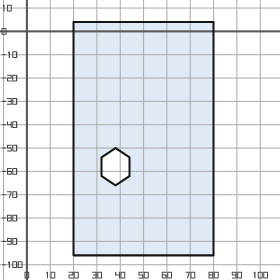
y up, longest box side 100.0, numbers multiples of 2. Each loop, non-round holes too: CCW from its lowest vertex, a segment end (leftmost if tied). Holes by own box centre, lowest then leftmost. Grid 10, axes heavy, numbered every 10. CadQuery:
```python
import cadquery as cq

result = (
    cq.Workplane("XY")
    .moveTo(20.0, -96.0)
    .lineTo(80.0, -96.0)
    .lineTo(80.0, 4.0)
    .lineTo(20.0, 4.0)
    .close()
    .moveTo(38.0, -66.0)
    .lineTo(44.0, -62.0)
    .lineTo(44.0, -54.0)
    .lineTo(38.0, -50.0)
    .lineTo(32.0, -54.0)
    .lineTo(32.0, -62.0)
    .close()
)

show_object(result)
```